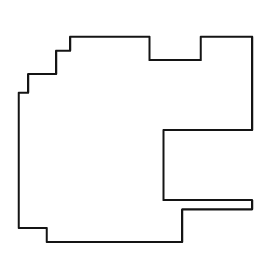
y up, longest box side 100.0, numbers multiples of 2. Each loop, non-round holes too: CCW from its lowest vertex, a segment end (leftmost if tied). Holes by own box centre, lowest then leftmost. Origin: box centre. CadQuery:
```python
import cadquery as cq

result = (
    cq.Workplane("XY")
    .moveTo(-38.0, -44.0)
    .lineTo(20.0, -44.0)
    .lineTo(20.0, -30.0)
    .lineTo(50.0, -30.0)
    .lineTo(50.0, -26.0)
    .lineTo(12.0, -26.0)
    .lineTo(12.0, 4.0)
    .lineTo(50.0, 4.0)
    .lineTo(50.0, 44.0)
    .lineTo(28.0, 44.0)
    .lineTo(28.0, 34.0)
    .lineTo(6.0, 34.0)
    .lineTo(6.0, 44.0)
    .lineTo(-28.0, 44.0)
    .lineTo(-28.0, 38.0)
    .lineTo(-34.0, 38.0)
    .lineTo(-34.0, 28.0)
    .lineTo(-46.0, 28.0)
    .lineTo(-46.0, 20.0)
    .lineTo(-50.0, 20.0)
    .lineTo(-50.0, -38.0)
    .lineTo(-38.0, -38.0)
    .close()
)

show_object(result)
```